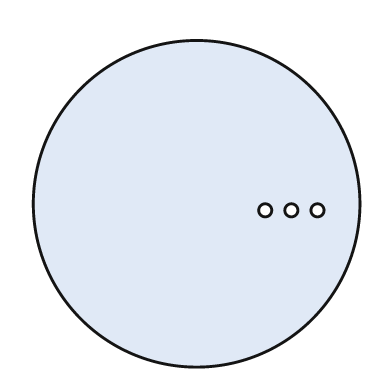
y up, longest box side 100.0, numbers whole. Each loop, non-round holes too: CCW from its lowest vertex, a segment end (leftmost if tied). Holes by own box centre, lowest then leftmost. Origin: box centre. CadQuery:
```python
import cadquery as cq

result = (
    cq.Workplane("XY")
    .moveTo(0.0, 0.0)
    .circle(50.0)
    .moveTo(21.0, -2.0)
    .circle(2.0)
    .moveTo(29.0, -2.0)
    .circle(2.0)
    .moveTo(37.0, -2.0)
    .circle(2.0)
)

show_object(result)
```